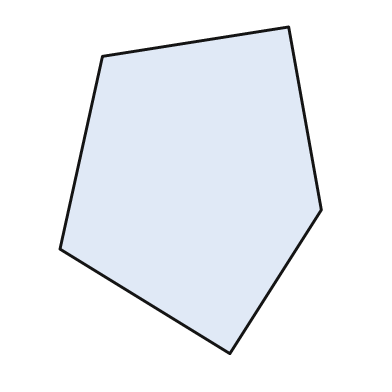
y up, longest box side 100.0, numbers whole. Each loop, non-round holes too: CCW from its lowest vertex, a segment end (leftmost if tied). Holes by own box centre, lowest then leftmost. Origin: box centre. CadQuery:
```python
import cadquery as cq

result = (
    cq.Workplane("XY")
    .moveTo(12.0, -50.0)
    .lineTo(40.0, -6.0)
    .lineTo(30.0, 50.0)
    .lineTo(-27.0, 41.0)
    .lineTo(-40.0, -18.0)
    .close()
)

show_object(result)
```